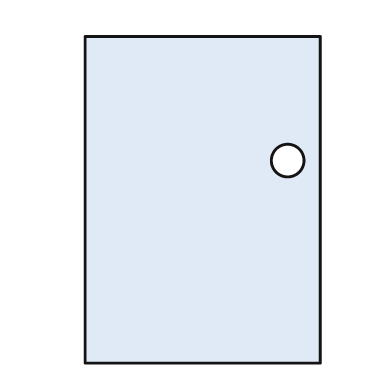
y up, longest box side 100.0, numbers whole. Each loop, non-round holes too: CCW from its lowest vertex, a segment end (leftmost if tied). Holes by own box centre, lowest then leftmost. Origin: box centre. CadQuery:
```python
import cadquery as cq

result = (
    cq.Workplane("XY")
    .moveTo(-36.0, -50.0)
    .lineTo(36.0, -50.0)
    .lineTo(36.0, 50.0)
    .lineTo(-36.0, 50.0)
    .close()
    .moveTo(26.0, 12.0)
    .circle(5.0)
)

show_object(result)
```